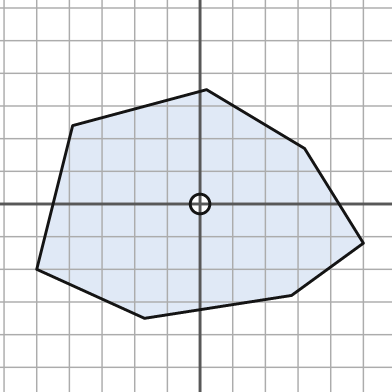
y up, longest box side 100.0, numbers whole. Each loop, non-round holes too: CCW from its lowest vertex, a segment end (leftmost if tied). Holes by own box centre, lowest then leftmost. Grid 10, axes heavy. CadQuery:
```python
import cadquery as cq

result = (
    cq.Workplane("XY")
    .moveTo(-17.0, -35.0)
    .lineTo(28.0, -28.0)
    .lineTo(50.0, -12.0)
    .lineTo(32.0, 17.0)
    .lineTo(2.0, 35.0)
    .lineTo(-39.0, 24.0)
    .lineTo(-50.0, -20.0)
    .close()
    .moveTo(0.0, 0.0)
    .circle(3.0)
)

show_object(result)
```